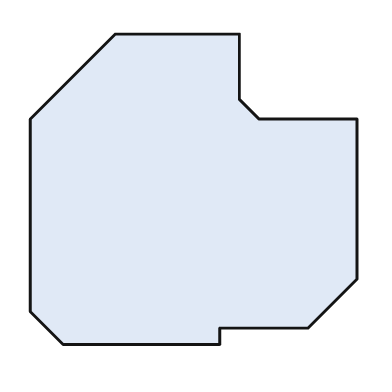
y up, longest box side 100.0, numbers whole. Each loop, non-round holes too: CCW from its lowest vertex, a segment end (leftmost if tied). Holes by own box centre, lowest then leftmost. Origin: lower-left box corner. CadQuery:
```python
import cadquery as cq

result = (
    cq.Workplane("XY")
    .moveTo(10.0, 0.0)
    .lineTo(58.0, 0.0)
    .lineTo(58.0, 5.0)
    .lineTo(85.0, 5.0)
    .lineTo(100.0, 20.0)
    .lineTo(100.0, 69.0)
    .lineTo(70.0, 69.0)
    .lineTo(64.0, 75.0)
    .lineTo(64.0, 95.0)
    .lineTo(26.0, 95.0)
    .lineTo(0.0, 69.0)
    .lineTo(0.0, 10.0)
    .close()
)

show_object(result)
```